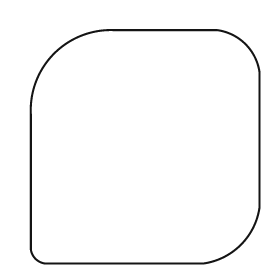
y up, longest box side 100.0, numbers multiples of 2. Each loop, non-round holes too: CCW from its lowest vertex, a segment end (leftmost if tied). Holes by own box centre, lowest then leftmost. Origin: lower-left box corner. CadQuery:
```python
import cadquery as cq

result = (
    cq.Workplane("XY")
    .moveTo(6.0, 0.0)
    .lineTo(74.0, 0.0)
    .threePointArc((90.0, 8.0), (98.0, 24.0))
    .lineTo(98.0, 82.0)
    .threePointArc((92.0, 94.0), (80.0, 100.0))
    .lineTo(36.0, 100.0)
    .threePointArc((10.0, 90.0), (0.0, 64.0))
    .lineTo(0.0, 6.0)
    .threePointArc((2.0, 2.0), (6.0, 0.0))
    .close()
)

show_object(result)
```